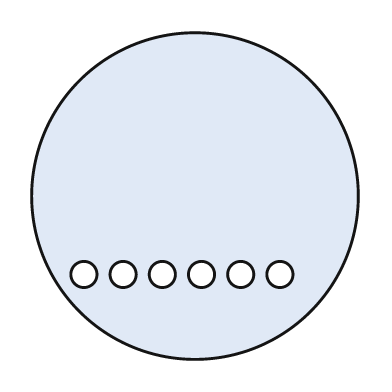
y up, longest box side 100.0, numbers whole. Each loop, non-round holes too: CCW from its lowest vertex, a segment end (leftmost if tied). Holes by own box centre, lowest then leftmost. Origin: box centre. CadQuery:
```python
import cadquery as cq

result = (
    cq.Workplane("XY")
    .moveTo(0.0, 0.0)
    .circle(50.0)
    .moveTo(-34.0, -24.0)
    .circle(4.0)
    .moveTo(-22.0, -24.0)
    .circle(4.0)
    .moveTo(-10.0, -24.0)
    .circle(4.0)
    .moveTo(2.0, -24.0)
    .circle(4.0)
    .moveTo(14.0, -24.0)
    .circle(4.0)
    .moveTo(26.0, -24.0)
    .circle(4.0)
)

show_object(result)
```